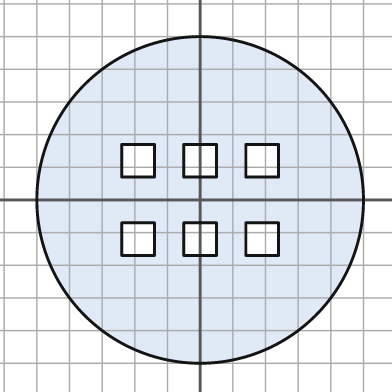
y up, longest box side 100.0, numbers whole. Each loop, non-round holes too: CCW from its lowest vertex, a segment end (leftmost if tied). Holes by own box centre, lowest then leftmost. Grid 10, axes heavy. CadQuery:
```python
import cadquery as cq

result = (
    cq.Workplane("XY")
    .moveTo(0.0, 0.0)
    .circle(50.0)
    .moveTo(-24.0, -17.0)
    .lineTo(-14.0, -17.0)
    .lineTo(-14.0, -7.0)
    .lineTo(-24.0, -7.0)
    .close()
    .moveTo(-5.0, -17.0)
    .lineTo(5.0, -17.0)
    .lineTo(5.0, -7.0)
    .lineTo(-5.0, -7.0)
    .close()
    .moveTo(14.0, -17.0)
    .lineTo(24.0, -17.0)
    .lineTo(24.0, -7.0)
    .lineTo(14.0, -7.0)
    .close()
    .moveTo(-24.0, 7.0)
    .lineTo(-14.0, 7.0)
    .lineTo(-14.0, 17.0)
    .lineTo(-24.0, 17.0)
    .close()
    .moveTo(-5.0, 7.0)
    .lineTo(5.0, 7.0)
    .lineTo(5.0, 17.0)
    .lineTo(-5.0, 17.0)
    .close()
    .moveTo(14.0, 7.0)
    .lineTo(24.0, 7.0)
    .lineTo(24.0, 17.0)
    .lineTo(14.0, 17.0)
    .close()
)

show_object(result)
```